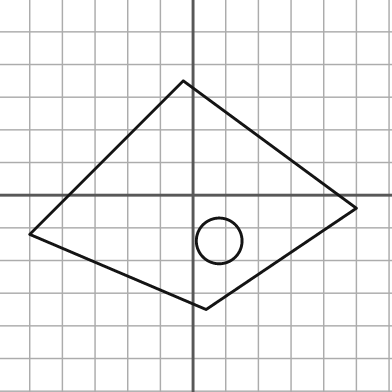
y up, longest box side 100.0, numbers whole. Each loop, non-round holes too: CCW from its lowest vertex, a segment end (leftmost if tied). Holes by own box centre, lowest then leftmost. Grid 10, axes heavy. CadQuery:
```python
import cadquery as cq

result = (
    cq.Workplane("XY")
    .moveTo(4.0, -35.0)
    .lineTo(50.0, -4.0)
    .lineTo(-3.0, 35.0)
    .lineTo(-50.0, -12.0)
    .close()
    .moveTo(8.0, -14.0)
    .circle(7.0)
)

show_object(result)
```